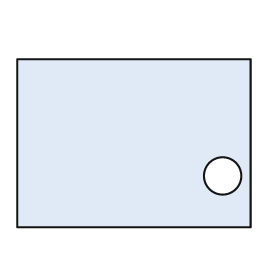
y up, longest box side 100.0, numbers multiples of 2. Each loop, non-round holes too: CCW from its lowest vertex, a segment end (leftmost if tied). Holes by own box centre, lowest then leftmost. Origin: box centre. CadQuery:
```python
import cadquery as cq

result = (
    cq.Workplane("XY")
    .moveTo(-50.0, -36.0)
    .lineTo(50.0, -36.0)
    .lineTo(50.0, 36.0)
    .lineTo(-50.0, 36.0)
    .close()
    .moveTo(38.0, -14.0)
    .circle(8.0)
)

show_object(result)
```